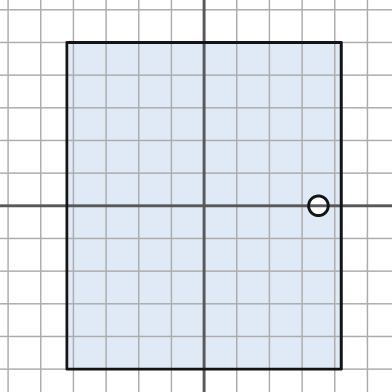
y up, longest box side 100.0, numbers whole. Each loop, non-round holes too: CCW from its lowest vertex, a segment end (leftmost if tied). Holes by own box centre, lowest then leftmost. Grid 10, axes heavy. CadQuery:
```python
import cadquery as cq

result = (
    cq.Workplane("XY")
    .moveTo(-42.0, -50.0)
    .lineTo(42.0, -50.0)
    .lineTo(42.0, 50.0)
    .lineTo(-42.0, 50.0)
    .close()
    .moveTo(35.0, 0.0)
    .circle(3.0)
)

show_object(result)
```